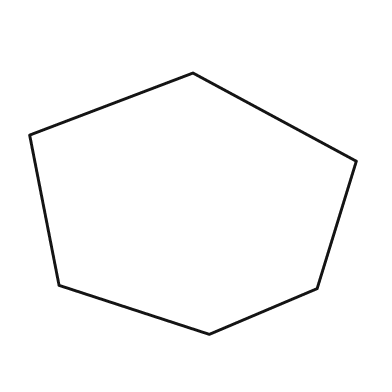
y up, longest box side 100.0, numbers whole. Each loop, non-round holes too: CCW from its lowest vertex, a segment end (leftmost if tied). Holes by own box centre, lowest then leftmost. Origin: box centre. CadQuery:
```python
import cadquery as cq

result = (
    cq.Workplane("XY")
    .moveTo(5.0, -40.0)
    .lineTo(38.0, -26.0)
    .lineTo(50.0, 13.0)
    .lineTo(0.0, 40.0)
    .lineTo(-50.0, 21.0)
    .lineTo(-41.0, -25.0)
    .close()
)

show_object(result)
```